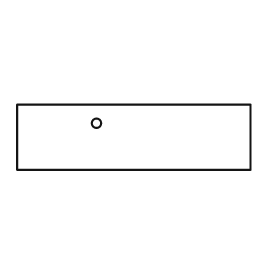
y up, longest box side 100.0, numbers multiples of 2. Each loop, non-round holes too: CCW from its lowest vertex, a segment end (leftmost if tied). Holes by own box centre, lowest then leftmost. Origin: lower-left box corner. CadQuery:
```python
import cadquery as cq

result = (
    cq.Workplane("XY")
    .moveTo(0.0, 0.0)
    .lineTo(100.0, 0.0)
    .lineTo(100.0, 28.0)
    .lineTo(0.0, 28.0)
    .close()
    .moveTo(34.0, 20.0)
    .circle(2.0)
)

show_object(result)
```